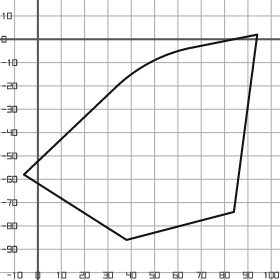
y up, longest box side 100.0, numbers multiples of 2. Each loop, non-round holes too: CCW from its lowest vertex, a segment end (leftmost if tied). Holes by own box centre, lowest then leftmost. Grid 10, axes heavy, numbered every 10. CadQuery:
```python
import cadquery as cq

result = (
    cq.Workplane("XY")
    .moveTo(38.0, -86.0)
    .lineTo(84.0, -74.0)
    .lineTo(94.0, 2.0)
    .lineTo(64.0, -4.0)
    .threePointArc((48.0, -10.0), (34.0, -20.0))
    .lineTo(-6.0, -58.0)
    .close()
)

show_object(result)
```